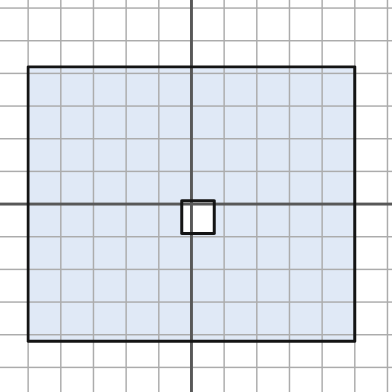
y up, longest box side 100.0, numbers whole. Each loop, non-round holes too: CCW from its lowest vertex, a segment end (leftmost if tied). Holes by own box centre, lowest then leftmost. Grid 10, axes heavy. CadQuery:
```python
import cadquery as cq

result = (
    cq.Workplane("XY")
    .moveTo(-50.0, -42.0)
    .lineTo(50.0, -42.0)
    .lineTo(50.0, 42.0)
    .lineTo(-50.0, 42.0)
    .close()
    .moveTo(-3.0, -9.0)
    .lineTo(7.0, -9.0)
    .lineTo(7.0, 1.0)
    .lineTo(-3.0, 1.0)
    .close()
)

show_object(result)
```